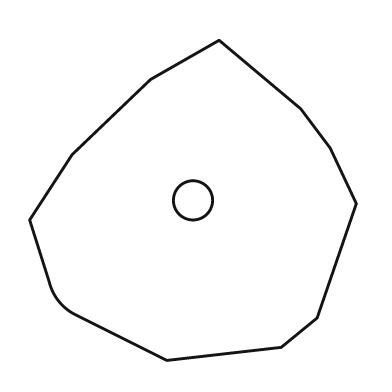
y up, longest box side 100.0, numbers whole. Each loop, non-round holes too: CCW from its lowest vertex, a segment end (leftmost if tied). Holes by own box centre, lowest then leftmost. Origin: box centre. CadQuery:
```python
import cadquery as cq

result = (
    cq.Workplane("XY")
    .moveTo(-8.0, -49.0)
    .lineTo(27.0, -45.0)
    .lineTo(38.0, -36.0)
    .lineTo(50.0, -1.0)
    .lineTo(42.0, 16.0)
    .lineTo(33.0, 28.0)
    .lineTo(8.0, 49.0)
    .lineTo(-13.0, 37.0)
    .lineTo(-37.0, 14.0)
    .lineTo(-50.0, -6.0)
    .lineTo(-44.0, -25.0)
    .threePointArc((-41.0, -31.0), (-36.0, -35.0))
    .close()
    .moveTo(0.0, 0.0)
    .circle(6.0)
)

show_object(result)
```